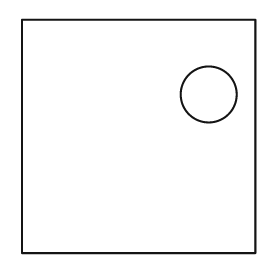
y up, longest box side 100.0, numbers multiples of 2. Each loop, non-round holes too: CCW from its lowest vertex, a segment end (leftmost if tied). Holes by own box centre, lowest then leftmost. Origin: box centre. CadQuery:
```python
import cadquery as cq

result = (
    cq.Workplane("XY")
    .moveTo(-50.0, -50.0)
    .lineTo(50.0, -50.0)
    .lineTo(50.0, 50.0)
    .lineTo(-50.0, 50.0)
    .close()
    .moveTo(30.0, 18.0)
    .circle(12.0)
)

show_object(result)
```